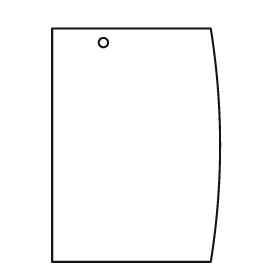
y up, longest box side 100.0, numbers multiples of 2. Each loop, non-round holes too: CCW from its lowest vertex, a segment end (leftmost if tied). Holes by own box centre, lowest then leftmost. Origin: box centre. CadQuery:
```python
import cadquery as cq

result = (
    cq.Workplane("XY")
    .moveTo(-36.0, -50.0)
    .lineTo(32.0, -50.0)
    .threePointArc((36.0, 0.0), (32.0, 50.0))
    .lineTo(-36.0, 50.0)
    .close()
    .moveTo(-14.0, 44.0)
    .circle(2.0)
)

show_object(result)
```